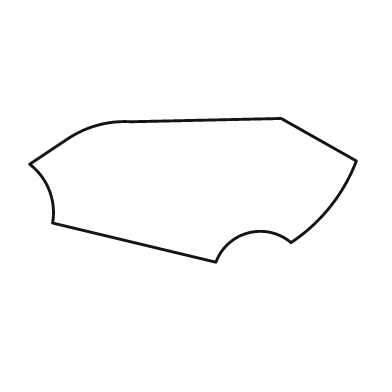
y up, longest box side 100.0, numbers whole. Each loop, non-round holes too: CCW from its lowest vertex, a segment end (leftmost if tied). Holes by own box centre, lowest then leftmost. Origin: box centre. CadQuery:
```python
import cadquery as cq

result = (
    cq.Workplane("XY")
    .moveTo(7.0, -22.0)
    .threePointArc((17.0, -13.0), (30.0, -16.0))
    .threePointArc((42.0, -5.0), (50.0, 9.0))
    .lineTo(27.0, 22.0)
    .lineTo(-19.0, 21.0)
    .threePointArc((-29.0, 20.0), (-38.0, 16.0))
    .lineTo(-50.0, 8.0)
    .threePointArc((-44.0, 0.0), (-43.0, -10.0))
    .close()
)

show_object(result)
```